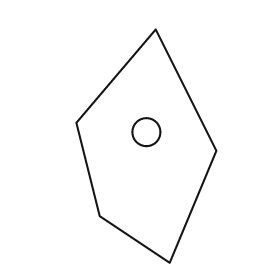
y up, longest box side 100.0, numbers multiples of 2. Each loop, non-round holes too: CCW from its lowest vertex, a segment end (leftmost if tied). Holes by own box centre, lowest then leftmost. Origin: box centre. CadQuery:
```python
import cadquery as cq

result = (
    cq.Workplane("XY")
    .moveTo(10.0, -50.0)
    .lineTo(30.0, -2.0)
    .lineTo(4.0, 50.0)
    .lineTo(-30.0, 10.0)
    .lineTo(-20.0, -30.0)
    .close()
    .moveTo(0.0, 6.0)
    .circle(6.0)
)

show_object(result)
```